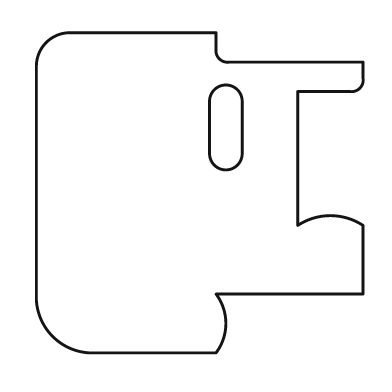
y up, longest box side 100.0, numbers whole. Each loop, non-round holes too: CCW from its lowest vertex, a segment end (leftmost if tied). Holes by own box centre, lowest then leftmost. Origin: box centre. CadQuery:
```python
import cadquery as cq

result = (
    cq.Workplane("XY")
    .moveTo(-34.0, -49.0)
    .lineTo(5.0, -49.0)
    .threePointArc((8.0, -40.0), (5.0, -31.0))
    .lineTo(50.0, -31.0)
    .lineTo(50.0, -10.0)
    .threePointArc((40.0, -7.0), (30.0, -10.0))
    .lineTo(30.0, 31.0)
    .lineTo(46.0, 31.0)
    .threePointArc((49.0, 32.0), (50.0, 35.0))
    .lineTo(50.0, 40.0)
    .lineTo(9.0, 40.0)
    .threePointArc((6.0, 41.0), (5.0, 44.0))
    .lineTo(5.0, 49.0)
    .lineTo(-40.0, 49.0)
    .threePointArc((-47.0, 46.0), (-50.0, 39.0))
    .lineTo(-50.0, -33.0)
    .threePointArc((-45.0, -44.0), (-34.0, -49.0))
    .close()
    .moveTo(3.0, 12.0)
    .threePointArc((8.0, 7.0), (13.0, 12.0))
    .lineTo(13.0, 28.0)
    .threePointArc((8.0, 33.0), (3.0, 28.0))
    .close()
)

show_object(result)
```